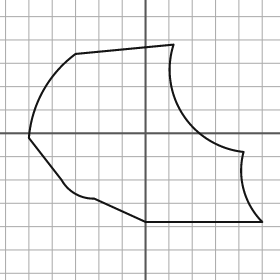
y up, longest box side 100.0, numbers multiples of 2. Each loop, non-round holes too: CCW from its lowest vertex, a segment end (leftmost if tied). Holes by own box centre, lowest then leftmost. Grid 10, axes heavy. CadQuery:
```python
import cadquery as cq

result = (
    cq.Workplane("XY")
    .moveTo(0.0, -38.0)
    .lineTo(50.0, -38.0)
    .threePointArc((42.0, -24.0), (42.0, -8.0))
    .threePointArc((16.0, 8.0), (12.0, 38.0))
    .lineTo(-30.0, 34.0)
    .threePointArc((-44.0, 18.0), (-50.0, -2.0))
    .lineTo(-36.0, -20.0)
    .threePointArc((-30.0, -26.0), (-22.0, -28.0))
    .close()
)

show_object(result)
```